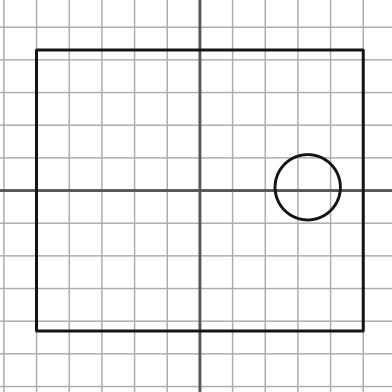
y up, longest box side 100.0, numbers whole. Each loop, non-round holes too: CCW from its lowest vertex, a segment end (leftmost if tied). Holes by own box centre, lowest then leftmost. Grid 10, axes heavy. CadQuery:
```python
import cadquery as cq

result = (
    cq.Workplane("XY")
    .moveTo(-50.0, -43.0)
    .lineTo(50.0, -43.0)
    .lineTo(50.0, 43.0)
    .lineTo(-50.0, 43.0)
    .close()
    .moveTo(33.0, 1.0)
    .circle(10.0)
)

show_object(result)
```